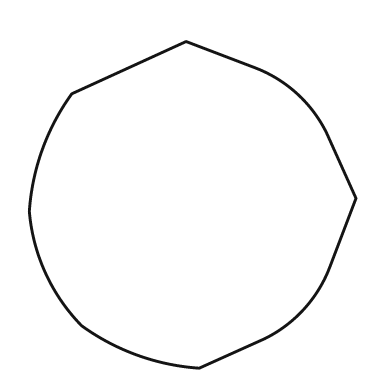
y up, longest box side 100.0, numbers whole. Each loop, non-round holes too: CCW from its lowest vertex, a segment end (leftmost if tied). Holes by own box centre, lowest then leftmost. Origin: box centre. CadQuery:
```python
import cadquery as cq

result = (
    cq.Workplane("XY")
    .moveTo(2.0, -50.0)
    .lineTo(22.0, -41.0)
    .threePointArc((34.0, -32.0), (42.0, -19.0))
    .lineTo(50.0, 2.0)
    .lineTo(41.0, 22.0)
    .threePointArc((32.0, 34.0), (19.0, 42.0))
    .lineTo(-2.0, 50.0)
    .lineTo(-37.0, 34.0)
    .threePointArc((-46.0, 17.0), (-50.0, -2.0))
    .threePointArc((-45.0, -21.0), (-34.0, -37.0))
    .threePointArc((-17.0, -46.0), (2.0, -50.0))
    .close()
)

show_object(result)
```